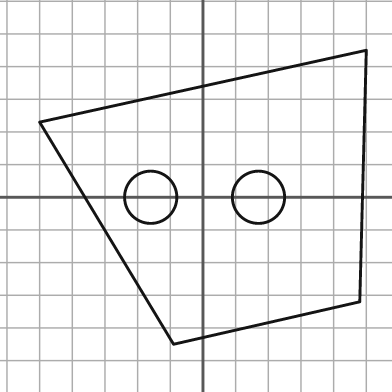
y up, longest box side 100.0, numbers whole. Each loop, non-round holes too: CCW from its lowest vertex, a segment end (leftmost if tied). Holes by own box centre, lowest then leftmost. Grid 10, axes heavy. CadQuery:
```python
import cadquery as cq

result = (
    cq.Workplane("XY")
    .moveTo(-9.0, -45.0)
    .lineTo(48.0, -32.0)
    .lineTo(50.0, 45.0)
    .lineTo(-50.0, 23.0)
    .close()
    .moveTo(-16.0, 0.0)
    .circle(8.0)
    .moveTo(17.0, 0.0)
    .circle(8.0)
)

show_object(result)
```